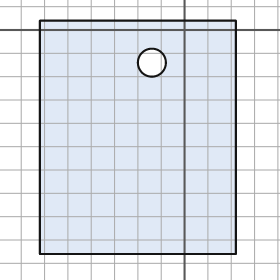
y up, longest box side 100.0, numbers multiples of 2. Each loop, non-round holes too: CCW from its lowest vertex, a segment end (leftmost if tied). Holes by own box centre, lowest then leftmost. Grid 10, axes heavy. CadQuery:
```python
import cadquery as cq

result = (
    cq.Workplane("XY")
    .moveTo(-62.0, -96.0)
    .lineTo(22.0, -96.0)
    .lineTo(22.0, 4.0)
    .lineTo(-62.0, 4.0)
    .close()
    .moveTo(-14.0, -14.0)
    .circle(6.0)
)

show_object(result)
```